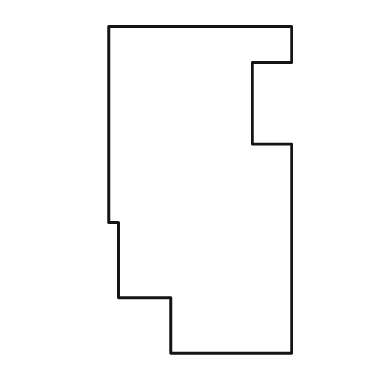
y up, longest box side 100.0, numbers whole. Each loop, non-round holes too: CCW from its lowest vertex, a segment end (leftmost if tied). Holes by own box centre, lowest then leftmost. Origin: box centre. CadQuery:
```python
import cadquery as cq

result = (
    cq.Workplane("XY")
    .moveTo(-9.0, -50.0)
    .lineTo(28.0, -50.0)
    .lineTo(28.0, 14.0)
    .lineTo(16.0, 14.0)
    .lineTo(16.0, 39.0)
    .lineTo(28.0, 39.0)
    .lineTo(28.0, 50.0)
    .lineTo(-28.0, 50.0)
    .lineTo(-28.0, -10.0)
    .lineTo(-25.0, -10.0)
    .lineTo(-25.0, -33.0)
    .lineTo(-9.0, -33.0)
    .close()
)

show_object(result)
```